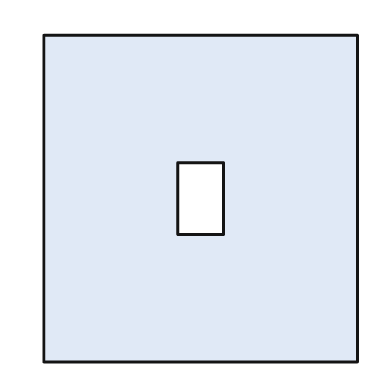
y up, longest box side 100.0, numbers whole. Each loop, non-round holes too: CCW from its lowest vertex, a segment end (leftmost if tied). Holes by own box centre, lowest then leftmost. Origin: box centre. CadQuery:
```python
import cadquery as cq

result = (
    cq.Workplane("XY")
    .moveTo(-48.0, -50.0)
    .lineTo(48.0, -50.0)
    .lineTo(48.0, 50.0)
    .lineTo(-48.0, 50.0)
    .close()
    .moveTo(-7.0, -11.0)
    .lineTo(7.0, -11.0)
    .lineTo(7.0, 11.0)
    .lineTo(-7.0, 11.0)
    .close()
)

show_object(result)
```